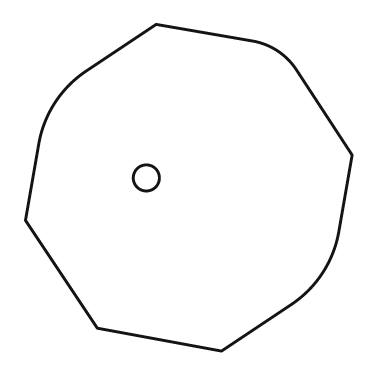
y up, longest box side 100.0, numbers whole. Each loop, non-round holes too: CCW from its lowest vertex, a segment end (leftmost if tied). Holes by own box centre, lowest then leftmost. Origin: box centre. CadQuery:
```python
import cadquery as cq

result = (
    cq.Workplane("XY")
    .moveTo(10.0, -50.0)
    .lineTo(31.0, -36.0)
    .threePointArc((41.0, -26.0), (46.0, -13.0))
    .lineTo(50.0, 10.0)
    .lineTo(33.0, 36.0)
    .threePointArc((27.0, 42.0), (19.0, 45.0))
    .lineTo(-10.0, 50.0)
    .lineTo(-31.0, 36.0)
    .threePointArc((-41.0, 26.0), (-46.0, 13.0))
    .lineTo(-50.0, -10.0)
    .lineTo(-28.0, -43.0)
    .close()
    .moveTo(-13.0, 3.0)
    .circle(4.0)
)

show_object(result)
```